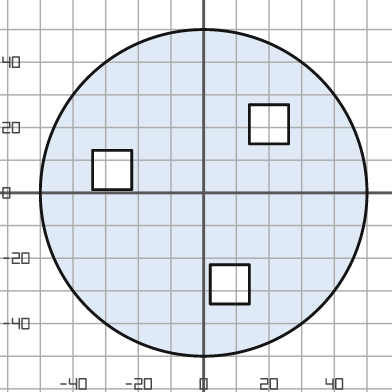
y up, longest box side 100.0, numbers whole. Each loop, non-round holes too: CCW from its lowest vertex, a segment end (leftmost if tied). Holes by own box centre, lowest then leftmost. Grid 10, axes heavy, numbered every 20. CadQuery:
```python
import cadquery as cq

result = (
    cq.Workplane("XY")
    .moveTo(0.0, 0.0)
    .circle(50.0)
    .moveTo(2.0, -34.0)
    .lineTo(14.0, -34.0)
    .lineTo(14.0, -22.0)
    .lineTo(2.0, -22.0)
    .close()
    .moveTo(-34.0, 1.0)
    .lineTo(-22.0, 1.0)
    .lineTo(-22.0, 13.0)
    .lineTo(-34.0, 13.0)
    .close()
    .moveTo(14.0, 15.0)
    .lineTo(26.0, 15.0)
    .lineTo(26.0, 27.0)
    .lineTo(14.0, 27.0)
    .close()
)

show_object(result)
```